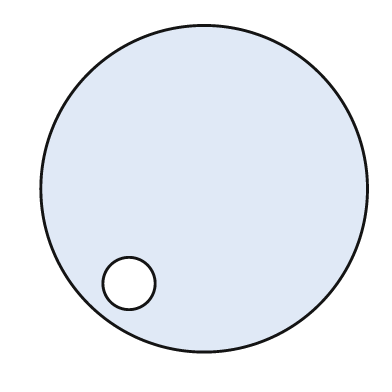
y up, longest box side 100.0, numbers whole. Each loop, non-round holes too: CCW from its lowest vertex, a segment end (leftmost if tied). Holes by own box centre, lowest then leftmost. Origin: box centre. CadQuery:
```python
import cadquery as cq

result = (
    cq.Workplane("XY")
    .moveTo(0.0, 0.0)
    .circle(50.0)
    .moveTo(-23.0, -29.0)
    .circle(8.0)
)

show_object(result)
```